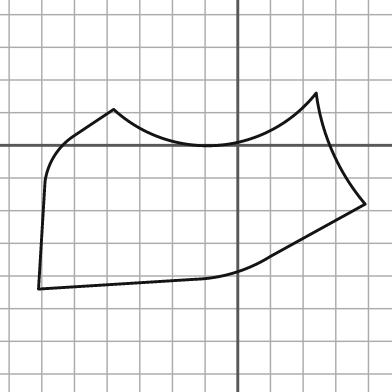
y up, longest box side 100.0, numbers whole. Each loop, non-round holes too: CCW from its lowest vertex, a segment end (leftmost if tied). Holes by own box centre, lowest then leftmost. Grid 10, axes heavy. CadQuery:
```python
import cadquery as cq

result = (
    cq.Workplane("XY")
    .moveTo(-61.0, -44.0)
    .lineTo(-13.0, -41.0)
    .threePointArc((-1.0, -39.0), (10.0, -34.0))
    .lineTo(39.0, -18.0)
    .threePointArc((29.0, -2.0), (24.0, 16.0))
    .threePointArc((-6.0, 0.0), (-38.0, 11.0))
    .lineTo(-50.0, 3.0)
    .threePointArc((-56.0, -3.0), (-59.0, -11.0))
    .close()
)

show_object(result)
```